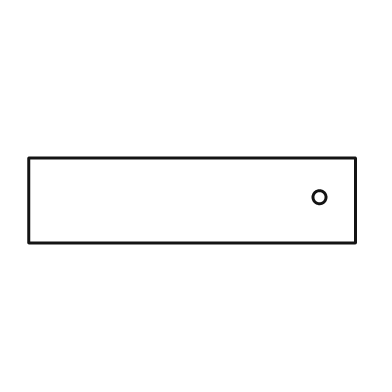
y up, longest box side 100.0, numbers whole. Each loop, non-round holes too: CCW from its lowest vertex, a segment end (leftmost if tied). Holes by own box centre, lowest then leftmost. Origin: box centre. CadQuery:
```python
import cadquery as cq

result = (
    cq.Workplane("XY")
    .moveTo(-50.0, -13.0)
    .lineTo(50.0, -13.0)
    .lineTo(50.0, 13.0)
    .lineTo(-50.0, 13.0)
    .close()
    .moveTo(39.0, 1.0)
    .circle(2.0)
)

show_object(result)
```